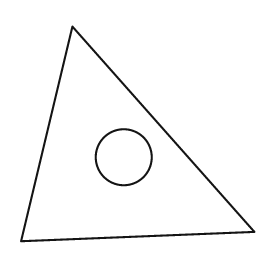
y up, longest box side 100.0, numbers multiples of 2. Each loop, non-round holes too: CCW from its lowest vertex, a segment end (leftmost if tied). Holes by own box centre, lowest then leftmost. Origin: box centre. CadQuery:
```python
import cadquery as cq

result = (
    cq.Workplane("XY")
    .moveTo(-50.0, -46.0)
    .lineTo(50.0, -42.0)
    .lineTo(-28.0, 46.0)
    .close()
    .moveTo(-6.0, -10.0)
    .circle(12.0)
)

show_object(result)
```